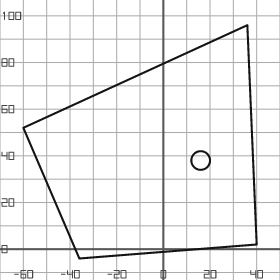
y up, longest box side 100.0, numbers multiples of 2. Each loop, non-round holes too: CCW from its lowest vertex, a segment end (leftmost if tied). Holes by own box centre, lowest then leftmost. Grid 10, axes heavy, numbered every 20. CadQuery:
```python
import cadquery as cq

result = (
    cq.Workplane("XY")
    .moveTo(-36.0, -4.0)
    .lineTo(40.0, 2.0)
    .lineTo(36.0, 96.0)
    .lineTo(-60.0, 52.0)
    .close()
    .moveTo(16.0, 38.0)
    .circle(4.0)
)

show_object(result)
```